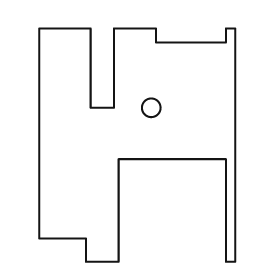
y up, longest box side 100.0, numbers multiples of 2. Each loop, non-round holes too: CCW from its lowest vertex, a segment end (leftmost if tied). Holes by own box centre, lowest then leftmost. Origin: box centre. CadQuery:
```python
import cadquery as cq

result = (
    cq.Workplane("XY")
    .moveTo(-22.0, -50.0)
    .lineTo(-8.0, -50.0)
    .lineTo(-8.0, -6.0)
    .lineTo(38.0, -6.0)
    .lineTo(38.0, -50.0)
    .lineTo(42.0, -50.0)
    .lineTo(42.0, 50.0)
    .lineTo(38.0, 50.0)
    .lineTo(38.0, 44.0)
    .lineTo(8.0, 44.0)
    .lineTo(8.0, 50.0)
    .lineTo(-10.0, 50.0)
    .lineTo(-10.0, 16.0)
    .lineTo(-20.0, 16.0)
    .lineTo(-20.0, 50.0)
    .lineTo(-42.0, 50.0)
    .lineTo(-42.0, -40.0)
    .lineTo(-22.0, -40.0)
    .close()
    .moveTo(6.0, 16.0)
    .circle(4.0)
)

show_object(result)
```